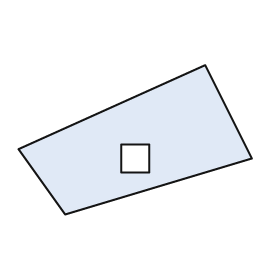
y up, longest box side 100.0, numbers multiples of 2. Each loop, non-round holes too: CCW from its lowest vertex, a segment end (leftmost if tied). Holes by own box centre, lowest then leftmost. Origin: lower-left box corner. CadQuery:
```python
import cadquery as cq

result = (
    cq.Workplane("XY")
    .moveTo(20.0, 0.0)
    .lineTo(100.0, 24.0)
    .lineTo(80.0, 64.0)
    .lineTo(0.0, 28.0)
    .close()
    .moveTo(44.0, 18.0)
    .lineTo(56.0, 18.0)
    .lineTo(56.0, 30.0)
    .lineTo(44.0, 30.0)
    .close()
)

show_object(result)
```